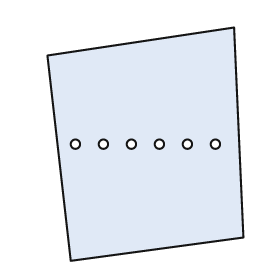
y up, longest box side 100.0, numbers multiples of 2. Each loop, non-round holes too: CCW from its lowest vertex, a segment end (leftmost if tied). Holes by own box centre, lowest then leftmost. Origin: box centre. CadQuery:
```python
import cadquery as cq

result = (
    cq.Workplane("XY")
    .moveTo(-32.0, -50.0)
    .lineTo(42.0, -40.0)
    .lineTo(38.0, 50.0)
    .lineTo(-42.0, 38.0)
    .close()
    .moveTo(-30.0, 0.0)
    .circle(2.0)
    .moveTo(-18.0, 0.0)
    .circle(2.0)
    .moveTo(-6.0, 0.0)
    .circle(2.0)
    .moveTo(6.0, 0.0)
    .circle(2.0)
    .moveTo(18.0, 0.0)
    .circle(2.0)
    .moveTo(30.0, 0.0)
    .circle(2.0)
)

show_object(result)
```